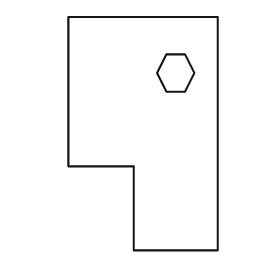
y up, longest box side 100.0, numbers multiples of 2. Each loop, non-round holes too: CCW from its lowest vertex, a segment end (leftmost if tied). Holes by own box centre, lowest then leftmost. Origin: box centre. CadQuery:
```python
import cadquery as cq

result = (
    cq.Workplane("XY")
    .moveTo(-4.0, -50.0)
    .lineTo(32.0, -50.0)
    .lineTo(32.0, 50.0)
    .lineTo(-32.0, 50.0)
    .lineTo(-32.0, -14.0)
    .lineTo(-4.0, -14.0)
    .close()
    .moveTo(10.0, 18.0)
    .lineTo(18.0, 18.0)
    .lineTo(22.0, 26.0)
    .lineTo(18.0, 34.0)
    .lineTo(10.0, 34.0)
    .lineTo(6.0, 26.0)
    .close()
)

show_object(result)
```